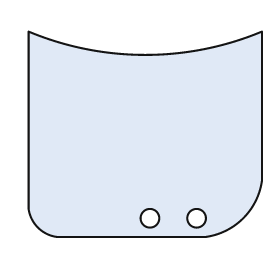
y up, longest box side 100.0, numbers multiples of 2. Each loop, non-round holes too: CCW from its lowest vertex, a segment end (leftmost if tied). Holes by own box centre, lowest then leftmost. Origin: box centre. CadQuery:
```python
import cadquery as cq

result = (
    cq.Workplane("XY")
    .moveTo(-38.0, -44.0)
    .lineTo(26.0, -44.0)
    .threePointArc((42.0, -36.0), (50.0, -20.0))
    .lineTo(50.0, 44.0)
    .threePointArc((0.0, 34.0), (-50.0, 44.0))
    .lineTo(-50.0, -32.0)
    .threePointArc((-46.0, -40.0), (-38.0, -44.0))
    .close()
    .moveTo(2.0, -36.0)
    .circle(4.0)
    .moveTo(22.0, -36.0)
    .circle(4.0)
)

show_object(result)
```